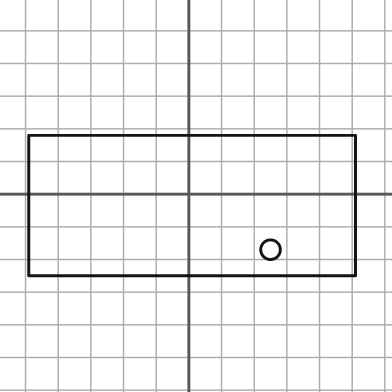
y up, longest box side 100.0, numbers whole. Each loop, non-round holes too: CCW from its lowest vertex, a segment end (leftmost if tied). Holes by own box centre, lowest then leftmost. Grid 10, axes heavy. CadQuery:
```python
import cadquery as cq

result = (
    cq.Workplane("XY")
    .moveTo(-49.0, -25.0)
    .lineTo(51.0, -25.0)
    .lineTo(51.0, 18.0)
    .lineTo(-49.0, 18.0)
    .close()
    .moveTo(25.0, -17.0)
    .circle(3.0)
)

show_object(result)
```